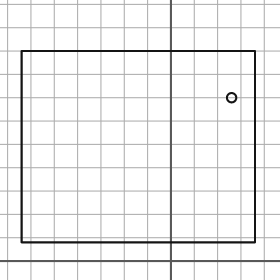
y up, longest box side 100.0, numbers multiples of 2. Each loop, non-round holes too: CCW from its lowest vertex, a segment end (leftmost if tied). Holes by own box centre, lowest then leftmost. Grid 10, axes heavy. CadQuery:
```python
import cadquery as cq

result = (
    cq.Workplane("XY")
    .moveTo(-64.0, 8.0)
    .lineTo(36.0, 8.0)
    .lineTo(36.0, 90.0)
    .lineTo(-64.0, 90.0)
    .close()
    .moveTo(26.0, 70.0)
    .circle(2.0)
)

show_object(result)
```